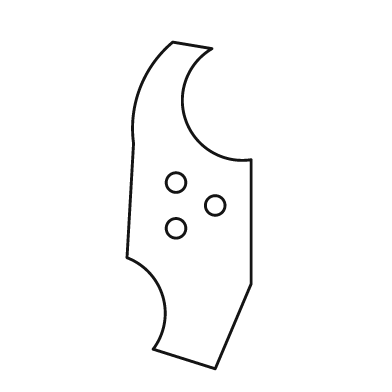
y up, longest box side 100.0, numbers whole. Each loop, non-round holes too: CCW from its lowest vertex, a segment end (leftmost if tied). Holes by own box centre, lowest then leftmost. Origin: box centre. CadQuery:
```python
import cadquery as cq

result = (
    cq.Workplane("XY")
    .moveTo(8.0, -50.0)
    .lineTo(19.0, -24.0)
    .lineTo(19.0, 14.0)
    .threePointArc((-1.0, 26.0), (7.0, 48.0))
    .lineTo(-5.0, 50.0)
    .threePointArc((-15.0, 36.0), (-17.0, 19.0))
    .lineTo(-19.0, -16.0)
    .threePointArc((-8.0, -28.0), (-11.0, -44.0))
    .close()
    .moveTo(-4.0, -7.0)
    .circle(3.0)
    .moveTo(8.0, 0.0)
    .circle(3.0)
    .moveTo(-4.0, 7.0)
    .circle(3.0)
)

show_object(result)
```